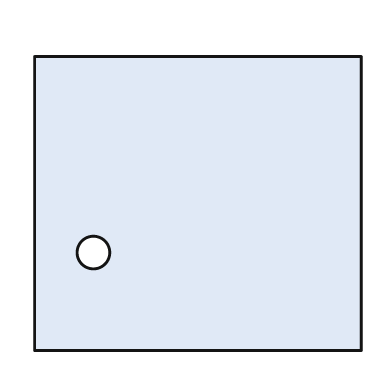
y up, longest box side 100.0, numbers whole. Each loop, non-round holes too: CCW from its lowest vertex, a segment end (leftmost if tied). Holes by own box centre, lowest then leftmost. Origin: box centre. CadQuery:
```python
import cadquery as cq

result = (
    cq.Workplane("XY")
    .moveTo(-50.0, -45.0)
    .lineTo(50.0, -45.0)
    .lineTo(50.0, 45.0)
    .lineTo(-50.0, 45.0)
    .close()
    .moveTo(-32.0, -15.0)
    .circle(5.0)
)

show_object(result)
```